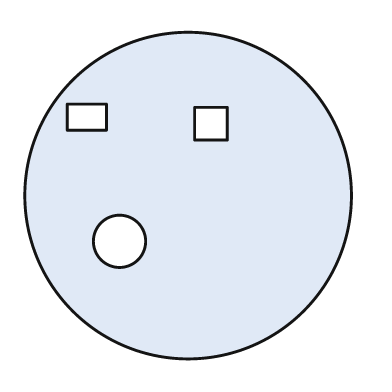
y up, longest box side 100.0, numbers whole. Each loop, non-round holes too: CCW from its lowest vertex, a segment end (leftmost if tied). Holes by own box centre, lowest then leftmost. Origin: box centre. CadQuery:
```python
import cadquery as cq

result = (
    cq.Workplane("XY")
    .moveTo(0.0, 0.0)
    .circle(50.0)
    .moveTo(-21.0, -14.0)
    .circle(8.0)
    .moveTo(2.0, 17.0)
    .lineTo(12.0, 17.0)
    .lineTo(12.0, 27.0)
    .lineTo(2.0, 27.0)
    .close()
    .moveTo(-37.0, 20.0)
    .lineTo(-25.0, 20.0)
    .lineTo(-25.0, 28.0)
    .lineTo(-37.0, 28.0)
    .close()
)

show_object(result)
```